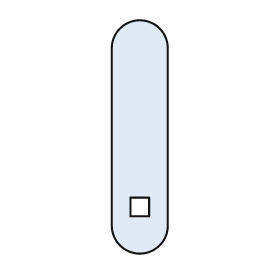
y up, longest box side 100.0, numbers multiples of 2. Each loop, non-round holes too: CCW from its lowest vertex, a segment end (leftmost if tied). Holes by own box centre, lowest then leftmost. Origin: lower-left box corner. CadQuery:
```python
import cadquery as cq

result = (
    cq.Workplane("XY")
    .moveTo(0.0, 12.0)
    .threePointArc((12.0, 0.0), (24.0, 12.0))
    .lineTo(24.0, 88.0)
    .threePointArc((12.0, 100.0), (0.0, 88.0))
    .close()
    .moveTo(8.0, 16.0)
    .lineTo(16.0, 16.0)
    .lineTo(16.0, 24.0)
    .lineTo(8.0, 24.0)
    .close()
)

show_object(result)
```